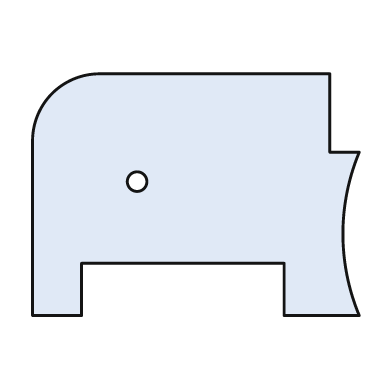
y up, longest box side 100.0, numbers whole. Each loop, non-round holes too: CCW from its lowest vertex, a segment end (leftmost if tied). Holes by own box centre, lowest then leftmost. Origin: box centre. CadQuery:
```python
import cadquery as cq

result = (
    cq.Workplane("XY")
    .moveTo(-50.0, -37.0)
    .lineTo(-35.0, -37.0)
    .lineTo(-35.0, -21.0)
    .lineTo(27.0, -21.0)
    .lineTo(27.0, -37.0)
    .lineTo(50.0, -37.0)
    .threePointArc((45.0, -12.0), (50.0, 13.0))
    .lineTo(41.0, 13.0)
    .lineTo(41.0, 37.0)
    .lineTo(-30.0, 37.0)
    .threePointArc((-44.0, 31.0), (-50.0, 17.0))
    .close()
    .moveTo(-18.0, 4.0)
    .circle(3.0)
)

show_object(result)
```